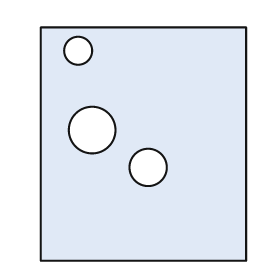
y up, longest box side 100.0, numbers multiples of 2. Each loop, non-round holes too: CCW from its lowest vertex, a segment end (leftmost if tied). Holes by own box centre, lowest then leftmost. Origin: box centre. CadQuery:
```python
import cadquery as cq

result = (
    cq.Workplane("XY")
    .moveTo(-44.0, -50.0)
    .lineTo(44.0, -50.0)
    .lineTo(44.0, 50.0)
    .lineTo(-44.0, 50.0)
    .close()
    .moveTo(2.0, -10.0)
    .circle(8.0)
    .moveTo(-22.0, 6.0)
    .circle(10.0)
    .moveTo(-28.0, 40.0)
    .circle(6.0)
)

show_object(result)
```